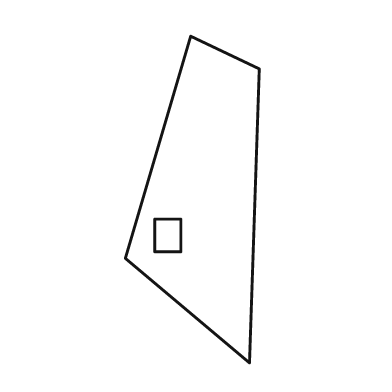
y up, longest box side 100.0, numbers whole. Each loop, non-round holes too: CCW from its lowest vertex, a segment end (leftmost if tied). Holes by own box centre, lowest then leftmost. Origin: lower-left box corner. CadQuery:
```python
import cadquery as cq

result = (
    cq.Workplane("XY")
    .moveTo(38.0, 0.0)
    .lineTo(41.0, 90.0)
    .lineTo(20.0, 100.0)
    .lineTo(0.0, 32.0)
    .close()
    .moveTo(9.0, 34.0)
    .lineTo(17.0, 34.0)
    .lineTo(17.0, 44.0)
    .lineTo(9.0, 44.0)
    .close()
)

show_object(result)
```